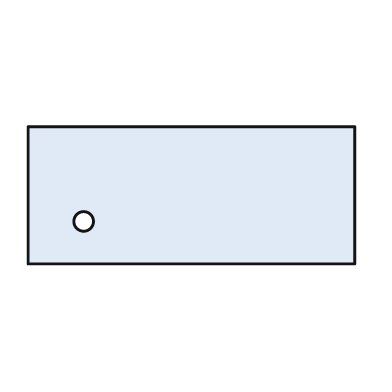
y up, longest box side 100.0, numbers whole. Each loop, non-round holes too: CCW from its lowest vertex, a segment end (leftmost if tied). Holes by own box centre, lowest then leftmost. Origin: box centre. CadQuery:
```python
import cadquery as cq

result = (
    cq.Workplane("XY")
    .moveTo(-50.0, -21.0)
    .lineTo(50.0, -21.0)
    .lineTo(50.0, 21.0)
    .lineTo(-50.0, 21.0)
    .close()
    .moveTo(-33.0, -8.0)
    .circle(3.0)
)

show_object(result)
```